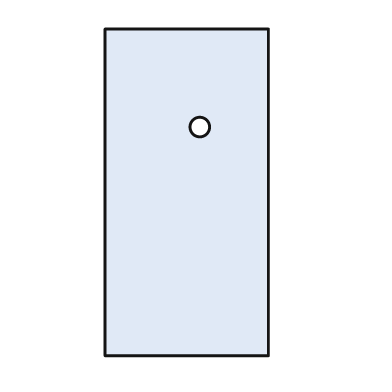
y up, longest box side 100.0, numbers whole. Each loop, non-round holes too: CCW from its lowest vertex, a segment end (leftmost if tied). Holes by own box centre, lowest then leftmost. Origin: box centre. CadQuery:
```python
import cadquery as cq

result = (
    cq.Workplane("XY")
    .moveTo(-25.0, -50.0)
    .lineTo(25.0, -50.0)
    .lineTo(25.0, 50.0)
    .lineTo(-25.0, 50.0)
    .close()
    .moveTo(4.0, 20.0)
    .circle(3.0)
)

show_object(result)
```